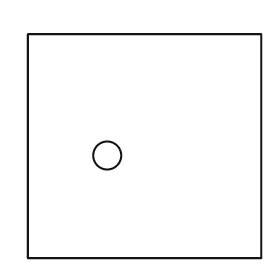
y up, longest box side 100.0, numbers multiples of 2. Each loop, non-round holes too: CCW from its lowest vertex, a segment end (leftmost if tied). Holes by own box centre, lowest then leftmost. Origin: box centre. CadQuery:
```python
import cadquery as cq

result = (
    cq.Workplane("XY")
    .moveTo(-50.0, -48.0)
    .lineTo(50.0, -48.0)
    .lineTo(50.0, 48.0)
    .lineTo(-50.0, 48.0)
    .close()
    .moveTo(-16.0, -4.0)
    .circle(6.0)
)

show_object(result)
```